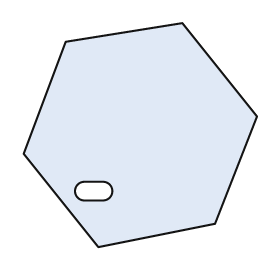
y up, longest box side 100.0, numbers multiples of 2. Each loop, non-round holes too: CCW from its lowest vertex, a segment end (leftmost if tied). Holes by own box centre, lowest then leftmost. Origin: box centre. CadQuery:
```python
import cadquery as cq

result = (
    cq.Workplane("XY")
    .moveTo(-18.0, -48.0)
    .lineTo(32.0, -38.0)
    .lineTo(50.0, 8.0)
    .lineTo(18.0, 48.0)
    .lineTo(-32.0, 40.0)
    .lineTo(-50.0, -8.0)
    .close()
    .moveTo(-24.0, -28.0)
    .lineTo(-16.0, -28.0)
    .threePointArc((-12.0, -24.0), (-16.0, -20.0))
    .lineTo(-24.0, -20.0)
    .threePointArc((-28.0, -24.0), (-24.0, -28.0))
    .close()
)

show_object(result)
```